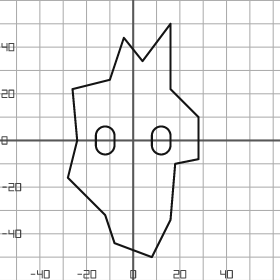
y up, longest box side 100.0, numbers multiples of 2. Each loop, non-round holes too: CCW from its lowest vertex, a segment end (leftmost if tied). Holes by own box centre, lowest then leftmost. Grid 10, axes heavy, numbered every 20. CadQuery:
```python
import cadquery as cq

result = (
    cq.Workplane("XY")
    .moveTo(8.0, -50.0)
    .lineTo(16.0, -34.0)
    .lineTo(18.0, -10.0)
    .lineTo(28.0, -8.0)
    .lineTo(28.0, 10.0)
    .lineTo(16.0, 22.0)
    .lineTo(16.0, 50.0)
    .lineTo(4.0, 34.0)
    .lineTo(-4.0, 44.0)
    .lineTo(-10.0, 26.0)
    .lineTo(-26.0, 22.0)
    .lineTo(-24.0, 0.0)
    .lineTo(-28.0, -16.0)
    .lineTo(-12.0, -32.0)
    .lineTo(-8.0, -44.0)
    .close()
    .moveTo(-16.0, -2.0)
    .threePointArc((-12.0, -6.0), (-8.0, -2.0))
    .lineTo(-8.0, 2.0)
    .threePointArc((-12.0, 6.0), (-16.0, 2.0))
    .close()
    .moveTo(8.0, -2.0)
    .threePointArc((12.0, -6.0), (16.0, -2.0))
    .lineTo(16.0, 2.0)
    .threePointArc((12.0, 6.0), (8.0, 2.0))
    .close()
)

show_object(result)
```